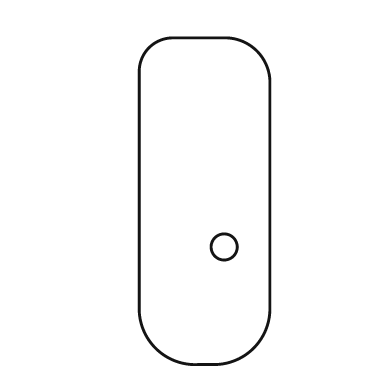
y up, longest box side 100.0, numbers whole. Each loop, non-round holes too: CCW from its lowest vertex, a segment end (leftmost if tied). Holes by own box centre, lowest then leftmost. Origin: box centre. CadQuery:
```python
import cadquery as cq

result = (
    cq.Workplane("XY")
    .moveTo(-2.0, -50.0)
    .lineTo(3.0, -50.0)
    .threePointArc((15.0, -45.0), (20.0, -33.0))
    .lineTo(20.0, 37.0)
    .threePointArc((16.0, 46.0), (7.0, 50.0))
    .lineTo(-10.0, 50.0)
    .threePointArc((-17.0, 47.0), (-20.0, 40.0))
    .lineTo(-20.0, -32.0)
    .threePointArc((-15.0, -45.0), (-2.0, -50.0))
    .close()
    .moveTo(6.0, -14.0)
    .circle(4.0)
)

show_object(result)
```